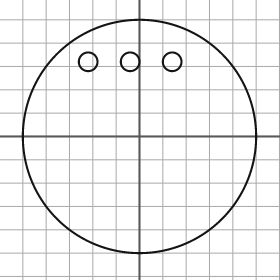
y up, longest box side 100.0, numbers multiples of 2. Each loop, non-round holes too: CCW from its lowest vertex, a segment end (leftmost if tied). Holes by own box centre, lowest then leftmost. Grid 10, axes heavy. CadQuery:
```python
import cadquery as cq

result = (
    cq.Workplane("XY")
    .moveTo(0.0, 0.0)
    .circle(50.0)
    .moveTo(-22.0, 32.0)
    .circle(4.0)
    .moveTo(-4.0, 32.0)
    .circle(4.0)
    .moveTo(14.0, 32.0)
    .circle(4.0)
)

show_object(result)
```